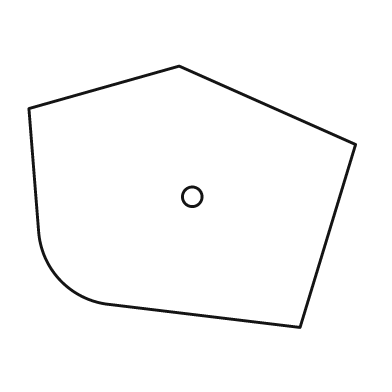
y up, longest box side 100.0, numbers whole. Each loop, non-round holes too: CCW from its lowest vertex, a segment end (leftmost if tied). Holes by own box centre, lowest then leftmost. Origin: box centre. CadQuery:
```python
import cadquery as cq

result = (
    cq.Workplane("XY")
    .moveTo(33.0, -40.0)
    .lineTo(50.0, 16.0)
    .lineTo(-4.0, 40.0)
    .lineTo(-50.0, 27.0)
    .lineTo(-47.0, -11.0)
    .threePointArc((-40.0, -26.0), (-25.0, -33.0))
    .close()
    .moveTo(0.0, 0.0)
    .circle(3.0)
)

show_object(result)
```